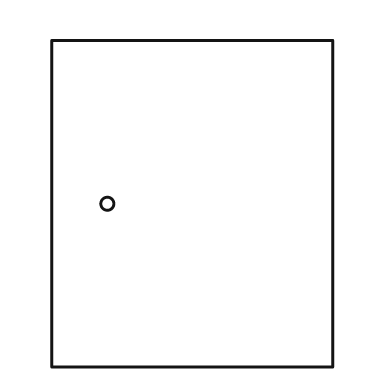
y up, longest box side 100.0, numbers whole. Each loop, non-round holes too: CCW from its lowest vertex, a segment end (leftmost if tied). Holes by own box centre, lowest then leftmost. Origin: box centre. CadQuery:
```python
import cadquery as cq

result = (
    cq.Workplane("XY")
    .moveTo(-43.0, -50.0)
    .lineTo(43.0, -50.0)
    .lineTo(43.0, 50.0)
    .lineTo(-43.0, 50.0)
    .close()
    .moveTo(-26.0, 0.0)
    .circle(2.0)
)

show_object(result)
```